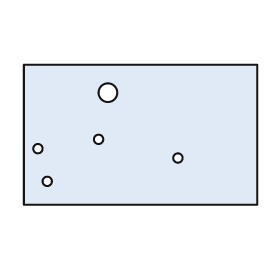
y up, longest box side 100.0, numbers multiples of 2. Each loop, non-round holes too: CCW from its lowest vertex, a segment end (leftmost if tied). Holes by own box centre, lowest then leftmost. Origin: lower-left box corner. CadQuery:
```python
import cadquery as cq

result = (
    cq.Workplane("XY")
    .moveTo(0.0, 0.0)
    .lineTo(100.0, 0.0)
    .lineTo(100.0, 60.0)
    .lineTo(0.0, 60.0)
    .close()
    .moveTo(10.0, 10.0)
    .circle(2.0)
    .moveTo(66.0, 20.0)
    .circle(2.0)
    .moveTo(6.0, 24.0)
    .circle(2.0)
    .moveTo(32.0, 28.0)
    .circle(2.0)
    .moveTo(36.0, 48.0)
    .circle(4.0)
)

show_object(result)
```